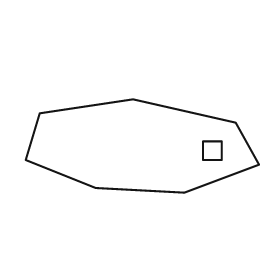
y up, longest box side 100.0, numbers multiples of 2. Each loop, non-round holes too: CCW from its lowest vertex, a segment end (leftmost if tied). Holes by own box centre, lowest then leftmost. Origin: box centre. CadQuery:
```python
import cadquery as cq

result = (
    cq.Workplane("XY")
    .moveTo(18.0, -20.0)
    .lineTo(50.0, -8.0)
    .lineTo(40.0, 10.0)
    .lineTo(-4.0, 20.0)
    .lineTo(-44.0, 14.0)
    .lineTo(-50.0, -6.0)
    .lineTo(-20.0, -18.0)
    .close()
    .moveTo(26.0, -6.0)
    .lineTo(34.0, -6.0)
    .lineTo(34.0, 2.0)
    .lineTo(26.0, 2.0)
    .close()
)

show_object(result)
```